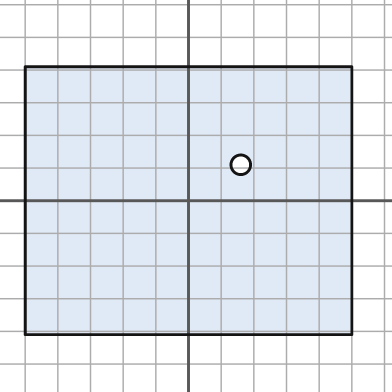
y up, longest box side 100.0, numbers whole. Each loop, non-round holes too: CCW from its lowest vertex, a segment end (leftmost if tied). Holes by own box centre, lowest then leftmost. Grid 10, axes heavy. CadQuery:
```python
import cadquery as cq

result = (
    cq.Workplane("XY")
    .moveTo(-50.0, -41.0)
    .lineTo(50.0, -41.0)
    .lineTo(50.0, 41.0)
    .lineTo(-50.0, 41.0)
    .close()
    .moveTo(16.0, 11.0)
    .circle(3.0)
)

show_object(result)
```